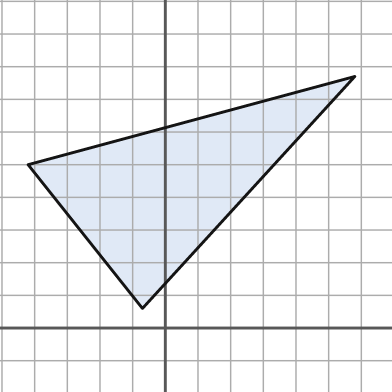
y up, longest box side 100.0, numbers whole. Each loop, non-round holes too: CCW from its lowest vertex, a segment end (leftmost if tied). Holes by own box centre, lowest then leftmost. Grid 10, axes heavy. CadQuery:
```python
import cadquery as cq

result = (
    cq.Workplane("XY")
    .moveTo(-7.0, 6.0)
    .lineTo(58.0, 77.0)
    .lineTo(-42.0, 50.0)
    .close()
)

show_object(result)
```